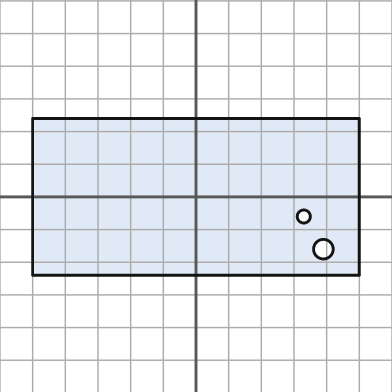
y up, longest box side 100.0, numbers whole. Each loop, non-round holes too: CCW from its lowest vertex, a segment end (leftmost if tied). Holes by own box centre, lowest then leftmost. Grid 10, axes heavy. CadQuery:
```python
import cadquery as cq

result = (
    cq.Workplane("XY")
    .moveTo(-50.0, -24.0)
    .lineTo(50.0, -24.0)
    .lineTo(50.0, 24.0)
    .lineTo(-50.0, 24.0)
    .close()
    .moveTo(39.0, -16.0)
    .circle(3.0)
    .moveTo(33.0, -6.0)
    .circle(2.0)
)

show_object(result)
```